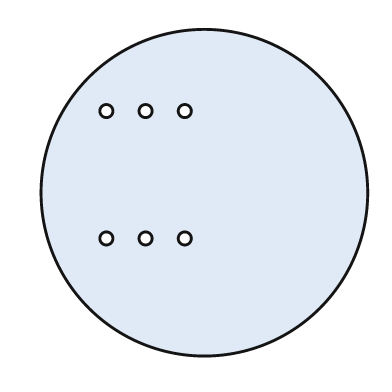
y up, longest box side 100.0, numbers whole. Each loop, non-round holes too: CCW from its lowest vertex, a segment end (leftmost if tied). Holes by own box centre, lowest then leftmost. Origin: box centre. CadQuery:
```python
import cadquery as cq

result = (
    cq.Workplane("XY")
    .moveTo(0.0, 0.0)
    .circle(50.0)
    .moveTo(-30.0, -14.0)
    .circle(2.0)
    .moveTo(-18.0, -14.0)
    .circle(2.0)
    .moveTo(-6.0, -14.0)
    .circle(2.0)
    .moveTo(-30.0, 25.0)
    .circle(2.0)
    .moveTo(-18.0, 25.0)
    .circle(2.0)
    .moveTo(-6.0, 25.0)
    .circle(2.0)
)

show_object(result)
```